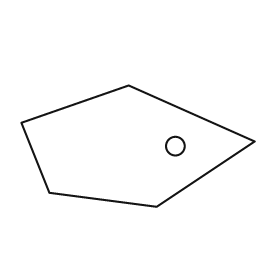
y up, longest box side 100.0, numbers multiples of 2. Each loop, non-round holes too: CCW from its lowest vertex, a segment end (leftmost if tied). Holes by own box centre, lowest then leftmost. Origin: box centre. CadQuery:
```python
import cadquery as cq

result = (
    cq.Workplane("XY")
    .moveTo(8.0, -26.0)
    .lineTo(50.0, 2.0)
    .lineTo(-4.0, 26.0)
    .lineTo(-50.0, 10.0)
    .lineTo(-38.0, -20.0)
    .close()
    .moveTo(16.0, 0.0)
    .circle(4.0)
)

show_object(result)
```